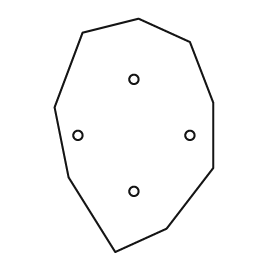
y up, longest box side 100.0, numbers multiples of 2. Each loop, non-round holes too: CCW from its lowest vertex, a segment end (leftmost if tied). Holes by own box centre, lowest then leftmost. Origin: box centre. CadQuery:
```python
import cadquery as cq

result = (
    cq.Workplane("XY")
    .moveTo(-8.0, -50.0)
    .lineTo(14.0, -40.0)
    .lineTo(34.0, -14.0)
    .lineTo(34.0, 14.0)
    .lineTo(24.0, 40.0)
    .lineTo(2.0, 50.0)
    .lineTo(-22.0, 44.0)
    .lineTo(-34.0, 12.0)
    .lineTo(-28.0, -18.0)
    .close()
    .moveTo(0.0, -24.0)
    .circle(2.0)
    .moveTo(-24.0, 0.0)
    .circle(2.0)
    .moveTo(24.0, 0.0)
    .circle(2.0)
    .moveTo(0.0, 24.0)
    .circle(2.0)
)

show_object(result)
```